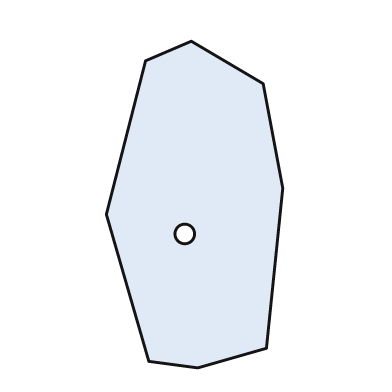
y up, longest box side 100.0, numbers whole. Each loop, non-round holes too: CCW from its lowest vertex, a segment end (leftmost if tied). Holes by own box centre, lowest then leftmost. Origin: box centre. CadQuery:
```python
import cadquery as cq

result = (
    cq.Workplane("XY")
    .moveTo(1.0, -50.0)
    .lineTo(22.0, -44.0)
    .lineTo(27.0, 5.0)
    .lineTo(21.0, 37.0)
    .lineTo(-1.0, 50.0)
    .lineTo(-15.0, 44.0)
    .lineTo(-27.0, -3.0)
    .lineTo(-14.0, -48.0)
    .close()
    .moveTo(-3.0, -9.0)
    .circle(3.0)
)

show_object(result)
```